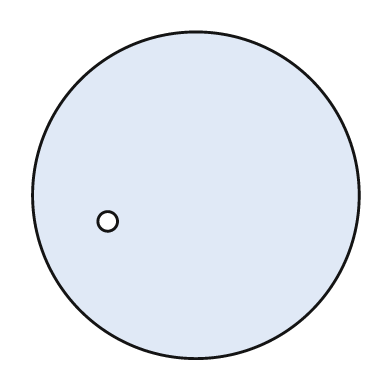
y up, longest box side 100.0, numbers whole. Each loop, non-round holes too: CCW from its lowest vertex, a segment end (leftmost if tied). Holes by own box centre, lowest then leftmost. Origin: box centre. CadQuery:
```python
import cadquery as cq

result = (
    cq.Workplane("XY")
    .moveTo(0.0, 0.0)
    .circle(50.0)
    .moveTo(-27.0, -8.0)
    .circle(3.0)
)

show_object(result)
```